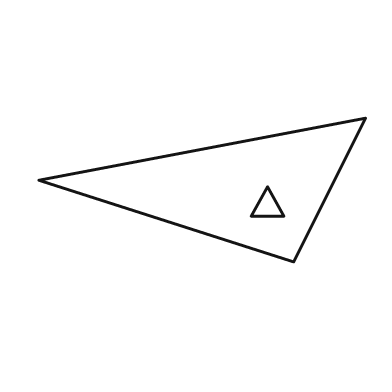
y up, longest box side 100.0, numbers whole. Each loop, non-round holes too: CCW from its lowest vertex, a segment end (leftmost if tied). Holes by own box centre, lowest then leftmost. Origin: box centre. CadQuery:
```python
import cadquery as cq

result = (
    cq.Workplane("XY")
    .moveTo(28.0, -22.0)
    .lineTo(50.0, 22.0)
    .lineTo(-50.0, 3.0)
    .close()
    .moveTo(15.0, -8.0)
    .lineTo(25.0, -8.0)
    .lineTo(20.0, 1.0)
    .close()
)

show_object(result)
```